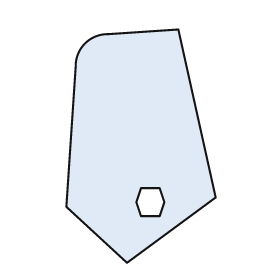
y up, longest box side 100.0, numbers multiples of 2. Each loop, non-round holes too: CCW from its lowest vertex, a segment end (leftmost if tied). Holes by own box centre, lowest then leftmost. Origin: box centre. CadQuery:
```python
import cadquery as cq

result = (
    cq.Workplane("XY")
    .moveTo(-6.0, -50.0)
    .lineTo(32.0, -22.0)
    .lineTo(16.0, 50.0)
    .lineTo(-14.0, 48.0)
    .threePointArc((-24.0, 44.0), (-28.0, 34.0))
    .lineTo(-32.0, -26.0)
    .close()
    .moveTo(0.0, -30.0)
    .lineTo(8.0, -30.0)
    .lineTo(10.0, -24.0)
    .lineTo(8.0, -18.0)
    .lineTo(0.0, -18.0)
    .lineTo(-2.0, -24.0)
    .close()
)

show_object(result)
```